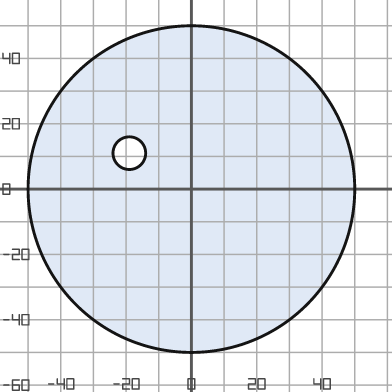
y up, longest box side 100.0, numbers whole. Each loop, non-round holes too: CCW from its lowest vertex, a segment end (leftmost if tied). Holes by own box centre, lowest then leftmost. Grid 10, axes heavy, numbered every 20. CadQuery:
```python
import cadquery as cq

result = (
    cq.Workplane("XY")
    .moveTo(0.0, 0.0)
    .circle(50.0)
    .moveTo(-19.0, 11.0)
    .circle(5.0)
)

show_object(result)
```